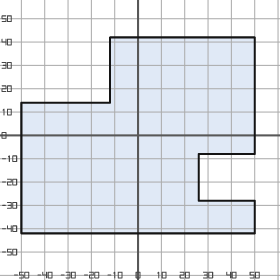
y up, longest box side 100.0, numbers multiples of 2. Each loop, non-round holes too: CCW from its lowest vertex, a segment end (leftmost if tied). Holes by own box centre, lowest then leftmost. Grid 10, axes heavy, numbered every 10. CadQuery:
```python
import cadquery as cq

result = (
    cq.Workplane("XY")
    .moveTo(-50.0, -42.0)
    .lineTo(50.0, -42.0)
    .lineTo(50.0, -28.0)
    .lineTo(26.0, -28.0)
    .lineTo(26.0, -8.0)
    .lineTo(50.0, -8.0)
    .lineTo(50.0, 42.0)
    .lineTo(-12.0, 42.0)
    .lineTo(-12.0, 14.0)
    .lineTo(-50.0, 14.0)
    .close()
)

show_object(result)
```